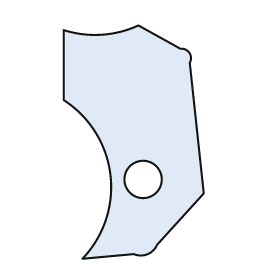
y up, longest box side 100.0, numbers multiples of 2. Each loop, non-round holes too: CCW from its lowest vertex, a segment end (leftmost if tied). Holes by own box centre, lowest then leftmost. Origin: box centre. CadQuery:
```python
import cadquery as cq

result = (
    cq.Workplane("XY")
    .moveTo(-22.0, -50.0)
    .lineTo(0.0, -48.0)
    .threePointArc((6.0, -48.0), (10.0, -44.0))
    .lineTo(30.0, -22.0)
    .lineTo(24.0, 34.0)
    .threePointArc((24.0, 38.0), (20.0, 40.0))
    .lineTo(2.0, 50.0)
    .threePointArc((-14.0, 46.0), (-30.0, 48.0))
    .lineTo(-30.0, 18.0)
    .threePointArc((-10.0, -14.0), (-22.0, -50.0))
    .close()
    .moveTo(4.0, -16.0)
    .circle(8.0)
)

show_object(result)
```